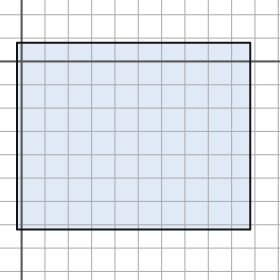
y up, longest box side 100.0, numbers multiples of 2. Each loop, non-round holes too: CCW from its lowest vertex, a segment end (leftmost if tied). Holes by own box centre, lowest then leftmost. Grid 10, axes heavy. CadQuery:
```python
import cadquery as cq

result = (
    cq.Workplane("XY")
    .moveTo(-2.0, -72.0)
    .lineTo(98.0, -72.0)
    .lineTo(98.0, 8.0)
    .lineTo(-2.0, 8.0)
    .close()
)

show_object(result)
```